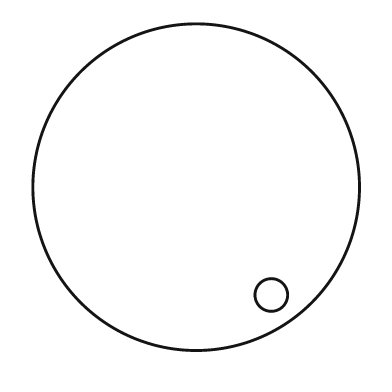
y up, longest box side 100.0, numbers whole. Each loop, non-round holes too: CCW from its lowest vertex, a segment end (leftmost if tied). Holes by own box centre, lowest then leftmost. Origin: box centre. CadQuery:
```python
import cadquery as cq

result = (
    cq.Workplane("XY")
    .moveTo(0.0, 0.0)
    .circle(50.0)
    .moveTo(23.0, -33.0)
    .circle(5.0)
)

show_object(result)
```